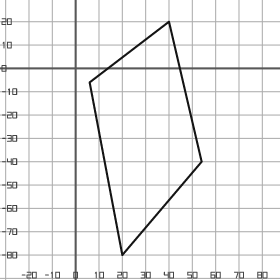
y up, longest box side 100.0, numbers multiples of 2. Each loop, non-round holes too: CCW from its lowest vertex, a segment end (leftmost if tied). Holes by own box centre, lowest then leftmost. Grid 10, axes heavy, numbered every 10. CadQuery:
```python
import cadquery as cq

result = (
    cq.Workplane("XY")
    .moveTo(20.0, -80.0)
    .lineTo(54.0, -40.0)
    .lineTo(40.0, 20.0)
    .lineTo(6.0, -6.0)
    .close()
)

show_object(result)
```